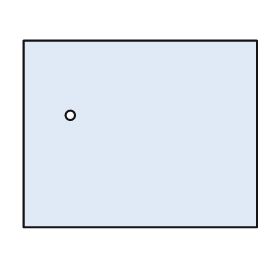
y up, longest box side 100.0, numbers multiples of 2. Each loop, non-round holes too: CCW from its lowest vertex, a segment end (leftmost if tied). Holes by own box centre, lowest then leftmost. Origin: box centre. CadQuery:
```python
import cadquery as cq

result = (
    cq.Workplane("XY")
    .moveTo(-50.0, -40.0)
    .lineTo(50.0, -40.0)
    .lineTo(50.0, 40.0)
    .lineTo(-50.0, 40.0)
    .close()
    .moveTo(-30.0, 8.0)
    .circle(2.0)
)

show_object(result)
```